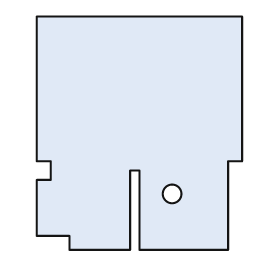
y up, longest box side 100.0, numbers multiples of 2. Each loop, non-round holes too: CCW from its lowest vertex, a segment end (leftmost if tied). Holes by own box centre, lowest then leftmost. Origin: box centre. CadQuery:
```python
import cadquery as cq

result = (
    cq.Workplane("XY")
    .moveTo(-30.0, -50.0)
    .lineTo(-4.0, -50.0)
    .lineTo(-4.0, -16.0)
    .lineTo(0.0, -16.0)
    .lineTo(0.0, -50.0)
    .lineTo(38.0, -50.0)
    .lineTo(38.0, -12.0)
    .lineTo(44.0, -12.0)
    .lineTo(44.0, 50.0)
    .lineTo(-44.0, 50.0)
    .lineTo(-44.0, -12.0)
    .lineTo(-38.0, -12.0)
    .lineTo(-38.0, -20.0)
    .lineTo(-44.0, -20.0)
    .lineTo(-44.0, -44.0)
    .lineTo(-30.0, -44.0)
    .close()
    .moveTo(14.0, -26.0)
    .circle(4.0)
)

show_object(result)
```